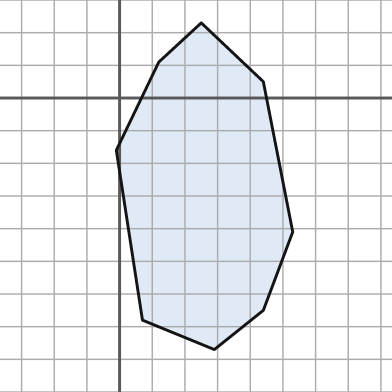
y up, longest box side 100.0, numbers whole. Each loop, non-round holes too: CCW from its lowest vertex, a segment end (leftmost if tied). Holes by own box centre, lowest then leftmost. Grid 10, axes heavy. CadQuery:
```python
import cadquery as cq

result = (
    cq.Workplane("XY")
    .moveTo(29.0, -77.0)
    .lineTo(44.0, -65.0)
    .lineTo(53.0, -41.0)
    .lineTo(44.0, 5.0)
    .lineTo(25.0, 23.0)
    .lineTo(12.0, 11.0)
    .lineTo(-1.0, -16.0)
    .lineTo(7.0, -68.0)
    .close()
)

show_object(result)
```